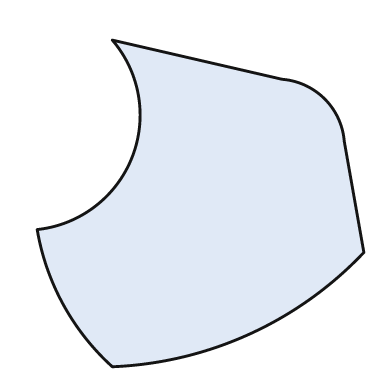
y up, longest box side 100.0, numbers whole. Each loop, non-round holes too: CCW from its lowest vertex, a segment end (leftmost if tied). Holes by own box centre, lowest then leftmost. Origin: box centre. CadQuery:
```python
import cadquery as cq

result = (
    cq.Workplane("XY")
    .moveTo(-27.0, -50.0)
    .threePointArc((15.0, -40.0), (50.0, -15.0))
    .lineTo(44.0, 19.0)
    .threePointArc((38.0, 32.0), (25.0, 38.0))
    .lineTo(-27.0, 50.0)
    .threePointArc((-21.0, 14.0), (-50.0, -8.0))
    .threePointArc((-42.0, -31.0), (-27.0, -50.0))
    .close()
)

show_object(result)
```